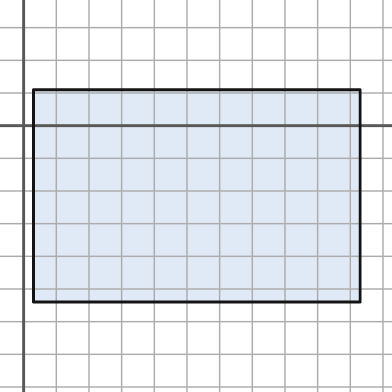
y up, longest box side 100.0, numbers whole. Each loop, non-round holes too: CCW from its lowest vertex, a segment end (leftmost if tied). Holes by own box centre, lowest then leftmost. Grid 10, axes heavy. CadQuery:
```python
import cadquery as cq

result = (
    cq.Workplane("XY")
    .moveTo(3.0, -54.0)
    .lineTo(103.0, -54.0)
    .lineTo(103.0, 11.0)
    .lineTo(3.0, 11.0)
    .close()
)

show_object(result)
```